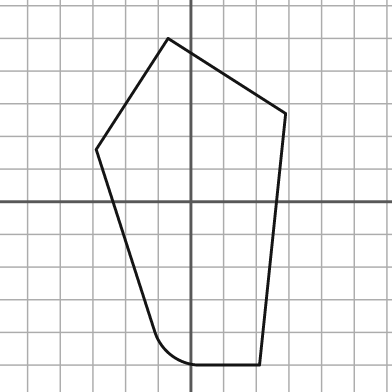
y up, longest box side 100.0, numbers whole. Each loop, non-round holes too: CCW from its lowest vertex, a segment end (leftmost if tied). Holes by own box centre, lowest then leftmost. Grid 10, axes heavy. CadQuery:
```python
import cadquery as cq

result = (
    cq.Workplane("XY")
    .moveTo(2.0, -50.0)
    .lineTo(21.0, -50.0)
    .lineTo(29.0, 27.0)
    .lineTo(-7.0, 50.0)
    .lineTo(-29.0, 16.0)
    .lineTo(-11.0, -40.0)
    .threePointArc((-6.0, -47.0), (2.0, -50.0))
    .close()
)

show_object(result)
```